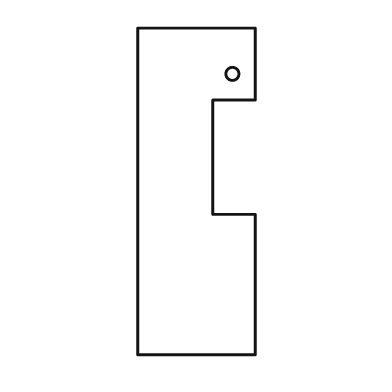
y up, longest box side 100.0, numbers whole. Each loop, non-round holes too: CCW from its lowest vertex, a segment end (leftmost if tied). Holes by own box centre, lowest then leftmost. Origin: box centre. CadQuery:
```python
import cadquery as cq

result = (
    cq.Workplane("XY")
    .moveTo(-18.0, -50.0)
    .lineTo(18.0, -50.0)
    .lineTo(18.0, -7.0)
    .lineTo(5.0, -7.0)
    .lineTo(5.0, 28.0)
    .lineTo(18.0, 28.0)
    .lineTo(18.0, 50.0)
    .lineTo(-18.0, 50.0)
    .close()
    .moveTo(11.0, 36.0)
    .circle(2.0)
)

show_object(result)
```